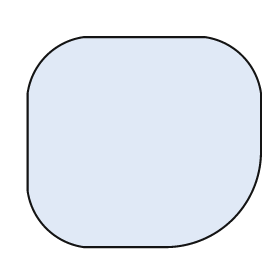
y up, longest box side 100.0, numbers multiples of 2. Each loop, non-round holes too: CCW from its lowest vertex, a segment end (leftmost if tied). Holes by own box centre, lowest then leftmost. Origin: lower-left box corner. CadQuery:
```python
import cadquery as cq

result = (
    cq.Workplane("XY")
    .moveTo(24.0, 0.0)
    .lineTo(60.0, 0.0)
    .threePointArc((88.0, 12.0), (100.0, 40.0))
    .lineTo(100.0, 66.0)
    .threePointArc((92.0, 82.0), (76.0, 90.0))
    .lineTo(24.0, 90.0)
    .threePointArc((8.0, 82.0), (0.0, 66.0))
    .lineTo(0.0, 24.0)
    .threePointArc((8.0, 8.0), (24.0, 0.0))
    .close()
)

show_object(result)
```